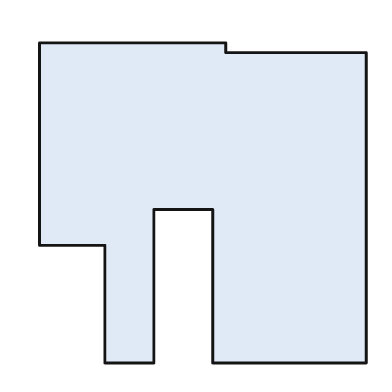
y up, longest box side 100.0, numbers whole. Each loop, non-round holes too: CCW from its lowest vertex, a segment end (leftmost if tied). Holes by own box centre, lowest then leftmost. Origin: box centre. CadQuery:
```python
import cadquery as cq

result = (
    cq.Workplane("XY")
    .moveTo(-30.0, -49.0)
    .lineTo(-15.0, -49.0)
    .lineTo(-15.0, -2.0)
    .lineTo(3.0, -2.0)
    .lineTo(3.0, -49.0)
    .lineTo(50.0, -49.0)
    .lineTo(50.0, 46.0)
    .lineTo(7.0, 46.0)
    .lineTo(7.0, 49.0)
    .lineTo(-50.0, 49.0)
    .lineTo(-50.0, -13.0)
    .lineTo(-30.0, -13.0)
    .close()
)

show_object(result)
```